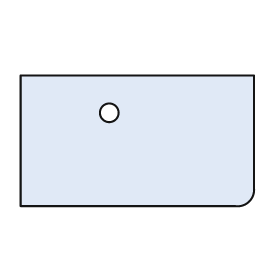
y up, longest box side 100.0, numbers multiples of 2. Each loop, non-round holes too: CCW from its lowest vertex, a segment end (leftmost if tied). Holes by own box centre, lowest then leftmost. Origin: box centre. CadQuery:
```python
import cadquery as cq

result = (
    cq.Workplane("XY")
    .moveTo(-50.0, -28.0)
    .lineTo(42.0, -28.0)
    .threePointArc((48.0, -26.0), (50.0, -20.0))
    .lineTo(50.0, 28.0)
    .lineTo(-50.0, 28.0)
    .close()
    .moveTo(-12.0, 12.0)
    .circle(4.0)
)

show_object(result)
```